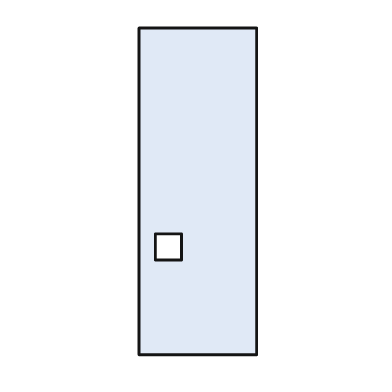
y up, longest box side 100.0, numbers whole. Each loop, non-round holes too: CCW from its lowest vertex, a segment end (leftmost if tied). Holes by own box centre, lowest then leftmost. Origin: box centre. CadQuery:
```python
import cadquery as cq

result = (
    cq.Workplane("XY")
    .moveTo(-18.0, -50.0)
    .lineTo(18.0, -50.0)
    .lineTo(18.0, 50.0)
    .lineTo(-18.0, 50.0)
    .close()
    .moveTo(-13.0, -21.0)
    .lineTo(-5.0, -21.0)
    .lineTo(-5.0, -13.0)
    .lineTo(-13.0, -13.0)
    .close()
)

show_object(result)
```